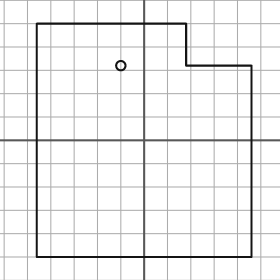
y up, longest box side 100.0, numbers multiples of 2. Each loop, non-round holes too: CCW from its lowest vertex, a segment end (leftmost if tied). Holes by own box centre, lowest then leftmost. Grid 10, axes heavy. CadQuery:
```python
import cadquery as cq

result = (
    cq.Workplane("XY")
    .moveTo(-46.0, -50.0)
    .lineTo(46.0, -50.0)
    .lineTo(46.0, 32.0)
    .lineTo(18.0, 32.0)
    .lineTo(18.0, 50.0)
    .lineTo(-46.0, 50.0)
    .close()
    .moveTo(-10.0, 32.0)
    .circle(2.0)
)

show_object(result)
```